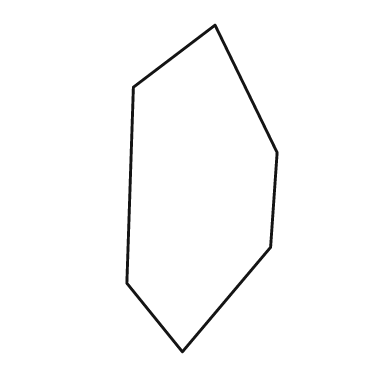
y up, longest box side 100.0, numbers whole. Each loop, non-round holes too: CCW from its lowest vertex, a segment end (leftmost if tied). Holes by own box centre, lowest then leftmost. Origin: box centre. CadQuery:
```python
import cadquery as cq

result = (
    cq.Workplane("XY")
    .moveTo(-6.0, -50.0)
    .lineTo(21.0, -18.0)
    .lineTo(23.0, 11.0)
    .lineTo(4.0, 50.0)
    .lineTo(-21.0, 31.0)
    .lineTo(-23.0, -29.0)
    .close()
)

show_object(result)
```